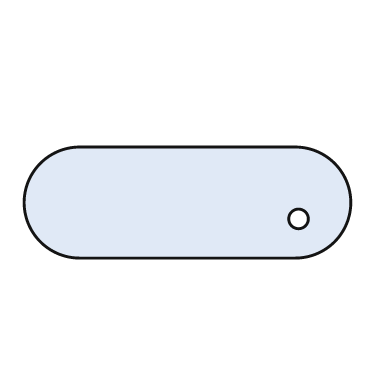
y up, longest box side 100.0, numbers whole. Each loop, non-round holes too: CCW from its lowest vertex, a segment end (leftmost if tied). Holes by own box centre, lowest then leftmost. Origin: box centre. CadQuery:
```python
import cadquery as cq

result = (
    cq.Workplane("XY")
    .moveTo(-33.0, -17.0)
    .lineTo(33.0, -17.0)
    .threePointArc((50.0, 0.0), (33.0, 17.0))
    .lineTo(-33.0, 17.0)
    .threePointArc((-50.0, 0.0), (-33.0, -17.0))
    .close()
    .moveTo(34.0, -5.0)
    .circle(3.0)
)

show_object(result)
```